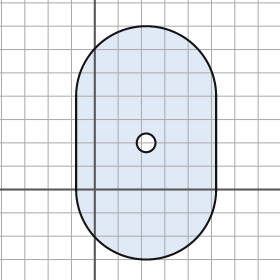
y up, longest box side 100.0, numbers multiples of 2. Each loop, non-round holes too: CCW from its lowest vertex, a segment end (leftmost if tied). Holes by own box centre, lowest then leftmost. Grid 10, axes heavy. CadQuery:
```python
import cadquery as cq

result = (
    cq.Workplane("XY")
    .moveTo(-8.0, 0.0)
    .threePointArc((22.0, -30.0), (52.0, 0.0))
    .lineTo(52.0, 40.0)
    .threePointArc((22.0, 70.0), (-8.0, 40.0))
    .close()
    .moveTo(22.0, 20.0)
    .circle(4.0)
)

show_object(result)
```